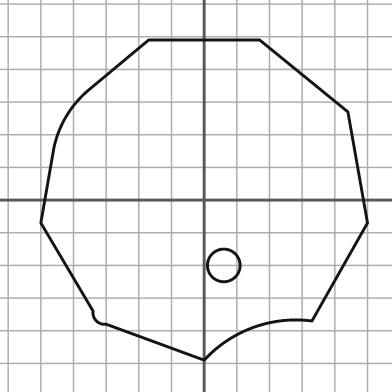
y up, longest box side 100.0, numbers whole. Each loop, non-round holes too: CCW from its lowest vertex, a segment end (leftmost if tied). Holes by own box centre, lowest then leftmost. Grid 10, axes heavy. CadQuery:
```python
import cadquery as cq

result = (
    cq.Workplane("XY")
    .moveTo(0.0, -49.0)
    .threePointArc((15.0, -39.0), (33.0, -37.0))
    .lineTo(50.0, -7.0)
    .lineTo(44.0, 27.0)
    .lineTo(17.0, 49.0)
    .lineTo(-17.0, 49.0)
    .lineTo(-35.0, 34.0)
    .threePointArc((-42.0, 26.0), (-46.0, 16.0))
    .lineTo(-50.0, -7.0)
    .lineTo(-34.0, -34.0)
    .threePointArc((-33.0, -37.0), (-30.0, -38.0))
    .close()
    .moveTo(6.0, -20.0)
    .circle(5.0)
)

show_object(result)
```